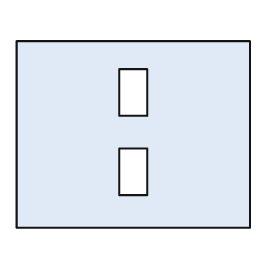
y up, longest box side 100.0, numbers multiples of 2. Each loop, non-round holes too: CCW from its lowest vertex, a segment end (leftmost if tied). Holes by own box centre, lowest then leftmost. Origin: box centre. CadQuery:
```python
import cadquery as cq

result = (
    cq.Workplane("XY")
    .moveTo(-50.0, -40.0)
    .lineTo(50.0, -40.0)
    .lineTo(50.0, 40.0)
    .lineTo(-50.0, 40.0)
    .close()
    .moveTo(-6.0, -26.0)
    .lineTo(6.0, -26.0)
    .lineTo(6.0, -6.0)
    .lineTo(-6.0, -6.0)
    .close()
    .moveTo(-6.0, 8.0)
    .lineTo(6.0, 8.0)
    .lineTo(6.0, 28.0)
    .lineTo(-6.0, 28.0)
    .close()
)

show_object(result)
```